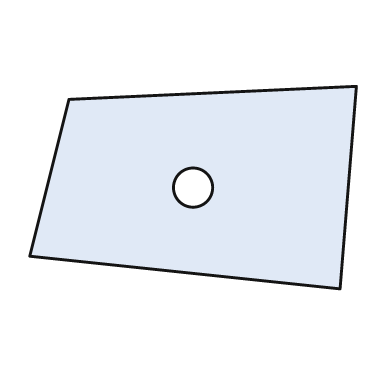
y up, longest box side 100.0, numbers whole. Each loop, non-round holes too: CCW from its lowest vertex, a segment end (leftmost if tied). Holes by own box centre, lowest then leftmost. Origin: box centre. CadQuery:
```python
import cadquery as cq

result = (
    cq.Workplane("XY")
    .moveTo(45.0, -31.0)
    .lineTo(50.0, 31.0)
    .lineTo(-38.0, 27.0)
    .lineTo(-50.0, -21.0)
    .close()
    .moveTo(0.0, 0.0)
    .circle(6.0)
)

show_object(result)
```